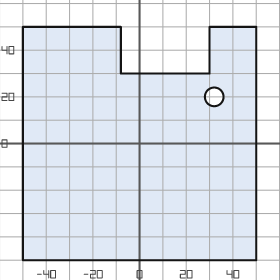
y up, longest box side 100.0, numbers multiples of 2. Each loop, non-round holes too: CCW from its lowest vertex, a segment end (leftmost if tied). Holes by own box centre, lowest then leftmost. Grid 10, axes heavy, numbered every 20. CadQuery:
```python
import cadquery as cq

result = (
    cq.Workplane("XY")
    .moveTo(-50.0, -50.0)
    .lineTo(50.0, -50.0)
    .lineTo(50.0, 50.0)
    .lineTo(30.0, 50.0)
    .lineTo(30.0, 30.0)
    .lineTo(-8.0, 30.0)
    .lineTo(-8.0, 50.0)
    .lineTo(-50.0, 50.0)
    .close()
    .moveTo(32.0, 20.0)
    .circle(4.0)
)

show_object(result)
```